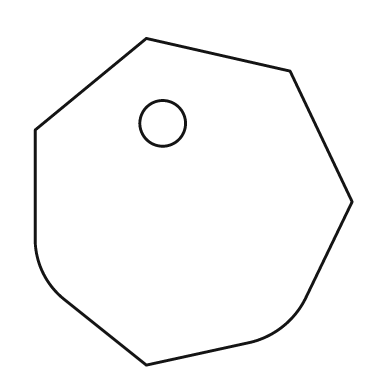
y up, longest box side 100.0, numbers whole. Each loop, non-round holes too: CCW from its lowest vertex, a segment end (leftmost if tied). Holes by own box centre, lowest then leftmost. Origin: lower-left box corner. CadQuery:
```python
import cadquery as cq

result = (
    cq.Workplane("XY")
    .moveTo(34.0, 0.0)
    .lineTo(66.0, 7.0)
    .threePointArc((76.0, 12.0), (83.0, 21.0))
    .lineTo(97.0, 50.0)
    .lineTo(78.0, 90.0)
    .lineTo(34.0, 100.0)
    .lineTo(0.0, 72.0)
    .lineTo(0.0, 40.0)
    .threePointArc((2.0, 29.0), (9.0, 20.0))
    .close()
    .moveTo(39.0, 74.0)
    .circle(7.0)
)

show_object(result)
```